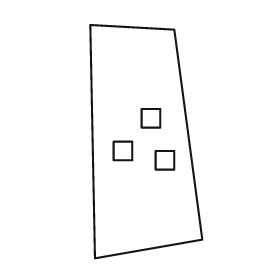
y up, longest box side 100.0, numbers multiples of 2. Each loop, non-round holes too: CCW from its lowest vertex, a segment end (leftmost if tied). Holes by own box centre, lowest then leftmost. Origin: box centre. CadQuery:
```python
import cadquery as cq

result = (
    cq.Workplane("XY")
    .moveTo(-22.0, -50.0)
    .lineTo(24.0, -42.0)
    .lineTo(12.0, 48.0)
    .lineTo(-24.0, 50.0)
    .close()
    .moveTo(4.0, -12.0)
    .lineTo(12.0, -12.0)
    .lineTo(12.0, -4.0)
    .lineTo(4.0, -4.0)
    .close()
    .moveTo(-14.0, -8.0)
    .lineTo(-6.0, -8.0)
    .lineTo(-6.0, 0.0)
    .lineTo(-14.0, 0.0)
    .close()
    .moveTo(-2.0, 6.0)
    .lineTo(6.0, 6.0)
    .lineTo(6.0, 14.0)
    .lineTo(-2.0, 14.0)
    .close()
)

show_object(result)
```